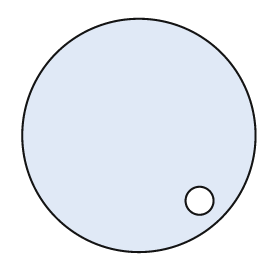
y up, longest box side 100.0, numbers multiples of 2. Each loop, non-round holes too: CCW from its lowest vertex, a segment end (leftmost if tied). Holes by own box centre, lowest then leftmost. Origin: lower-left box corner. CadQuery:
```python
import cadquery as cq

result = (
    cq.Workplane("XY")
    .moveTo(50.0, 50.0)
    .circle(50.0)
    .moveTo(76.0, 22.0)
    .circle(6.0)
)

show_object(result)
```